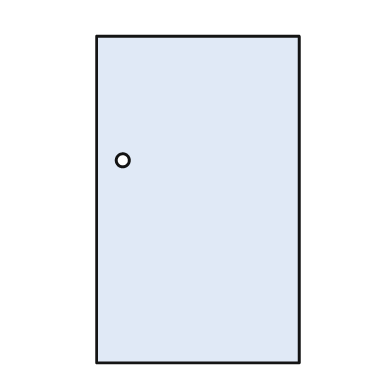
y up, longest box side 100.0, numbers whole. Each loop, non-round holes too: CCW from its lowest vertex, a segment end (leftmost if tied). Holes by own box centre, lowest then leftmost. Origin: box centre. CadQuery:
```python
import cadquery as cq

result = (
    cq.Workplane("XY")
    .moveTo(-31.0, -50.0)
    .lineTo(31.0, -50.0)
    .lineTo(31.0, 50.0)
    .lineTo(-31.0, 50.0)
    .close()
    .moveTo(-23.0, 12.0)
    .circle(2.0)
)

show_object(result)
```